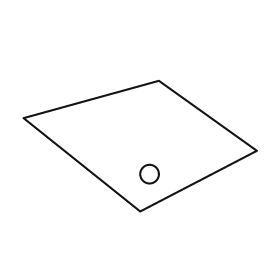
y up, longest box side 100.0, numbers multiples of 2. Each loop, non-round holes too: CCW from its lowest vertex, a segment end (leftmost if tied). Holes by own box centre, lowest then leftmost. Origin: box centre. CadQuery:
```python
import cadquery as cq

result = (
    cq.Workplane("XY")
    .moveTo(0.0, -28.0)
    .lineTo(50.0, -2.0)
    .lineTo(8.0, 28.0)
    .lineTo(-50.0, 12.0)
    .close()
    .moveTo(4.0, -12.0)
    .circle(4.0)
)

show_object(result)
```